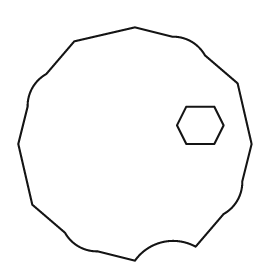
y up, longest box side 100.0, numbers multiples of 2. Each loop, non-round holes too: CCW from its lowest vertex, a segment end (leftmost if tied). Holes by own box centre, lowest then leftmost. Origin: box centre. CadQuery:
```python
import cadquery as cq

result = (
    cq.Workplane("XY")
    .moveTo(0.0, -50.0)
    .threePointArc((12.0, -42.0), (26.0, -44.0))
    .lineTo(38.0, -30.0)
    .threePointArc((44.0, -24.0), (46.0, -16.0))
    .lineTo(50.0, 0.0)
    .lineTo(44.0, 26.0)
    .lineTo(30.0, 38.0)
    .threePointArc((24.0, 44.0), (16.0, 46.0))
    .lineTo(0.0, 50.0)
    .lineTo(-26.0, 44.0)
    .lineTo(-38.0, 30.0)
    .threePointArc((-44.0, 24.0), (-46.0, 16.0))
    .lineTo(-50.0, 0.0)
    .lineTo(-44.0, -26.0)
    .lineTo(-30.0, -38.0)
    .threePointArc((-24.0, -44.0), (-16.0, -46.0))
    .close()
    .moveTo(22.0, 0.0)
    .lineTo(34.0, 0.0)
    .lineTo(38.0, 8.0)
    .lineTo(34.0, 16.0)
    .lineTo(22.0, 16.0)
    .lineTo(18.0, 8.0)
    .close()
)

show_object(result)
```